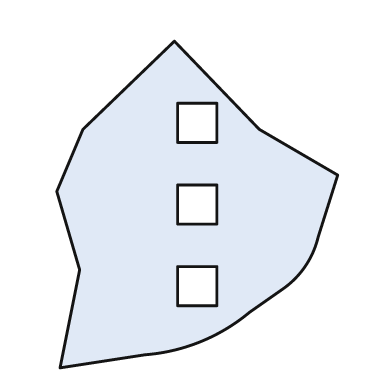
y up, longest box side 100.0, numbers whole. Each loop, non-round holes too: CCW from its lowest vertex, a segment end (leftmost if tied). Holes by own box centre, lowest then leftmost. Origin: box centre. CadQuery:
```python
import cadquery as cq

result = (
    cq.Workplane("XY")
    .moveTo(-42.0, -50.0)
    .lineTo(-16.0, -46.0)
    .threePointArc((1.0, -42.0), (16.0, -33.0))
    .lineTo(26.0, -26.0)
    .threePointArc((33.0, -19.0), (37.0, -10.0))
    .lineTo(43.0, 9.0)
    .lineTo(19.0, 23.0)
    .lineTo(-7.0, 50.0)
    .lineTo(-35.0, 23.0)
    .lineTo(-43.0, 4.0)
    .lineTo(-36.0, -20.0)
    .close()
    .moveTo(-6.0, -31.0)
    .lineTo(6.0, -31.0)
    .lineTo(6.0, -19.0)
    .lineTo(-6.0, -19.0)
    .close()
    .moveTo(-6.0, -6.0)
    .lineTo(6.0, -6.0)
    .lineTo(6.0, 6.0)
    .lineTo(-6.0, 6.0)
    .close()
    .moveTo(-6.0, 19.0)
    .lineTo(6.0, 19.0)
    .lineTo(6.0, 31.0)
    .lineTo(-6.0, 31.0)
    .close()
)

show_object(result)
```